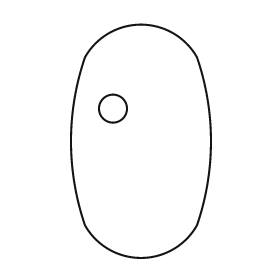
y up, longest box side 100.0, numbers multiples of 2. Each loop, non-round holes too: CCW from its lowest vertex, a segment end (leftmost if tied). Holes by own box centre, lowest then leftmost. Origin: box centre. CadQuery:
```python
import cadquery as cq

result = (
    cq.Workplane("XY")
    .moveTo(-24.0, -36.0)
    .threePointArc((0.0, -50.0), (24.0, -36.0))
    .threePointArc((30.0, 0.0), (24.0, 36.0))
    .threePointArc((0.0, 50.0), (-24.0, 36.0))
    .threePointArc((-30.0, 0.0), (-24.0, -36.0))
    .close()
    .moveTo(-12.0, 14.0)
    .circle(6.0)
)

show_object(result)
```